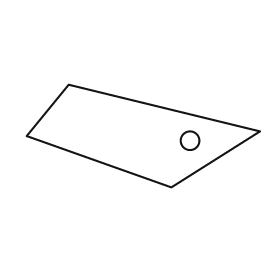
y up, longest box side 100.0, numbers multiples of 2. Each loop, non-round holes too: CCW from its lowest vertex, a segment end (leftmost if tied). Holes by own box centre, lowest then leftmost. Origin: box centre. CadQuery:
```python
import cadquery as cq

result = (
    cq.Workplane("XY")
    .moveTo(12.0, -22.0)
    .lineTo(50.0, 2.0)
    .lineTo(-32.0, 22.0)
    .lineTo(-50.0, 0.0)
    .close()
    .moveTo(20.0, -2.0)
    .circle(4.0)
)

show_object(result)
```